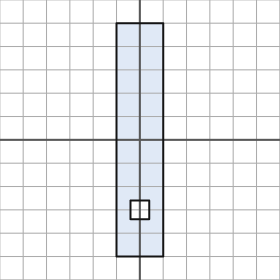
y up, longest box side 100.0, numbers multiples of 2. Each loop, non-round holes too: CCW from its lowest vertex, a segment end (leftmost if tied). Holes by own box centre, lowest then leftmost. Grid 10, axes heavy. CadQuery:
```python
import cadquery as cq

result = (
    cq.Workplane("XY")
    .moveTo(-10.0, -50.0)
    .lineTo(10.0, -50.0)
    .lineTo(10.0, 50.0)
    .lineTo(-10.0, 50.0)
    .close()
    .moveTo(-4.0, -34.0)
    .lineTo(4.0, -34.0)
    .lineTo(4.0, -26.0)
    .lineTo(-4.0, -26.0)
    .close()
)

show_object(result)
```